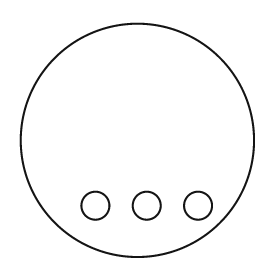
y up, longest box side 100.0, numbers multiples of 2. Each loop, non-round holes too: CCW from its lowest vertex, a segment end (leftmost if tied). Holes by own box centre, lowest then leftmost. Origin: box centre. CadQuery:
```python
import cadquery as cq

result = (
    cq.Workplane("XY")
    .moveTo(0.0, 0.0)
    .circle(50.0)
    .moveTo(-18.0, -28.0)
    .circle(6.0)
    .moveTo(4.0, -28.0)
    .circle(6.0)
    .moveTo(26.0, -28.0)
    .circle(6.0)
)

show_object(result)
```